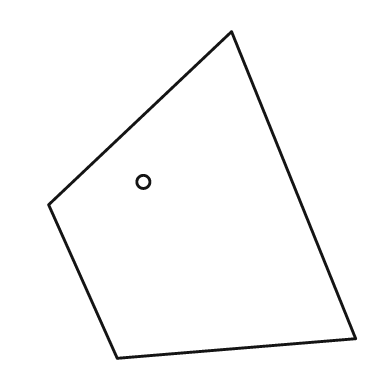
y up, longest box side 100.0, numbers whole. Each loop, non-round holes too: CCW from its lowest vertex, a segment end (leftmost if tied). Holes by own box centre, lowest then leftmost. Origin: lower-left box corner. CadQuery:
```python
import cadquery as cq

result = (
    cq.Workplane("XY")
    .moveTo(21.0, 0.0)
    .lineTo(94.0, 6.0)
    .lineTo(56.0, 100.0)
    .lineTo(0.0, 47.0)
    .close()
    .moveTo(29.0, 54.0)
    .circle(2.0)
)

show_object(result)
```